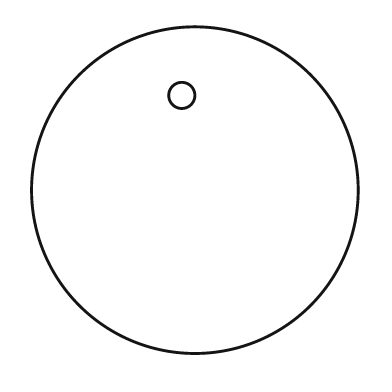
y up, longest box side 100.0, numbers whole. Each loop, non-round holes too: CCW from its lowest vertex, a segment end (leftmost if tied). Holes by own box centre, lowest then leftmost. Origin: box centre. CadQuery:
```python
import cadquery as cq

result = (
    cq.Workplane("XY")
    .moveTo(0.0, 0.0)
    .circle(50.0)
    .moveTo(-4.0, 29.0)
    .circle(4.0)
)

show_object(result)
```